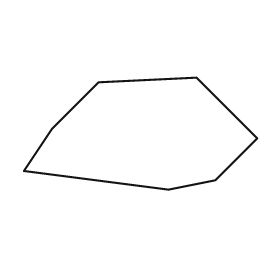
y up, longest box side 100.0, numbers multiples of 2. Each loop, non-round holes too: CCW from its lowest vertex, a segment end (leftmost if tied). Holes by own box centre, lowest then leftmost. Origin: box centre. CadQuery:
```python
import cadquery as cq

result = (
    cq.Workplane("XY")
    .moveTo(12.0, -24.0)
    .lineTo(32.0, -20.0)
    .lineTo(50.0, -2.0)
    .lineTo(24.0, 24.0)
    .lineTo(-18.0, 22.0)
    .lineTo(-38.0, 2.0)
    .lineTo(-50.0, -16.0)
    .close()
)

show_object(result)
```